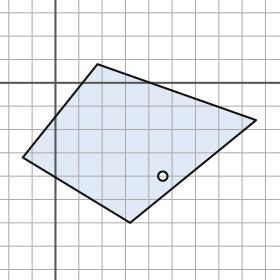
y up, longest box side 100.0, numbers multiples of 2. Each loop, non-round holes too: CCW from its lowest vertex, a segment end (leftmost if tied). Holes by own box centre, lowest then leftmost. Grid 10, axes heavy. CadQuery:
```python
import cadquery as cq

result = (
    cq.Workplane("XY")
    .moveTo(32.0, -60.0)
    .lineTo(86.0, -16.0)
    .lineTo(18.0, 8.0)
    .lineTo(-14.0, -32.0)
    .close()
    .moveTo(46.0, -40.0)
    .circle(2.0)
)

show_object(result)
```